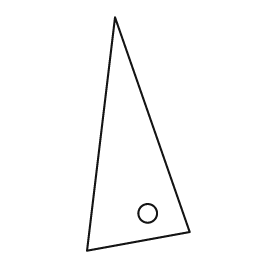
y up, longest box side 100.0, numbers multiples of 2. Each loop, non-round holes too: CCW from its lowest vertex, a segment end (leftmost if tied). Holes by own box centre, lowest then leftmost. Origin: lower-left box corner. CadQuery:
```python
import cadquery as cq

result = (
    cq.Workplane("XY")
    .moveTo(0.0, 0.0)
    .lineTo(44.0, 8.0)
    .lineTo(12.0, 100.0)
    .close()
    .moveTo(26.0, 16.0)
    .circle(4.0)
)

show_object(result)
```